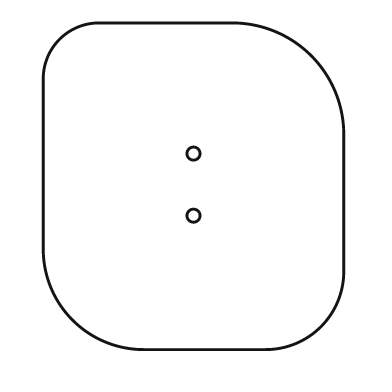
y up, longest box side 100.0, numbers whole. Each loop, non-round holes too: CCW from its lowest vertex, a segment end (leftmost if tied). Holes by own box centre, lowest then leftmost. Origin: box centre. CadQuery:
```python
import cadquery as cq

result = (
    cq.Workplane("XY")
    .moveTo(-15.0, -50.0)
    .lineTo(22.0, -50.0)
    .threePointArc((39.0, -43.0), (46.0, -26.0))
    .lineTo(46.0, 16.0)
    .threePointArc((36.0, 40.0), (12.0, 50.0))
    .lineTo(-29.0, 50.0)
    .threePointArc((-41.0, 45.0), (-46.0, 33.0))
    .lineTo(-46.0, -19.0)
    .threePointArc((-37.0, -41.0), (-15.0, -50.0))
    .close()
    .moveTo(0.0, -9.0)
    .circle(2.0)
    .moveTo(0.0, 10.0)
    .circle(2.0)
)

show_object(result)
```